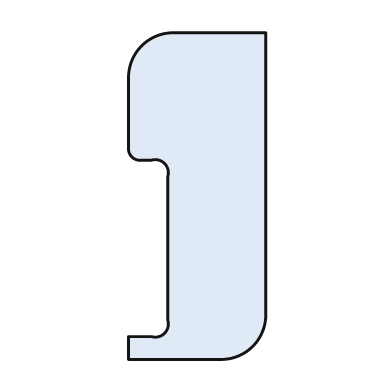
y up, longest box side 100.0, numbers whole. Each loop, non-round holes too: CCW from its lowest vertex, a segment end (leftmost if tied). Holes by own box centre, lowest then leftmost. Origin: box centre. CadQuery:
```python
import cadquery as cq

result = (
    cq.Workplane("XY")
    .moveTo(-21.0, -50.0)
    .lineTo(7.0, -50.0)
    .threePointArc((17.0, -46.0), (21.0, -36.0))
    .lineTo(21.0, 50.0)
    .lineTo(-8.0, 50.0)
    .threePointArc((-17.0, 46.0), (-21.0, 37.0))
    .lineTo(-21.0, 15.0)
    .threePointArc((-20.0, 12.0), (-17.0, 11.0))
    .lineTo(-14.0, 11.0)
    .threePointArc((-10.0, 10.0), (-9.0, 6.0))
    .lineTo(-9.0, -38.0)
    .threePointArc((-10.0, -42.0), (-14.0, -43.0))
    .lineTo(-21.0, -43.0)
    .close()
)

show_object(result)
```